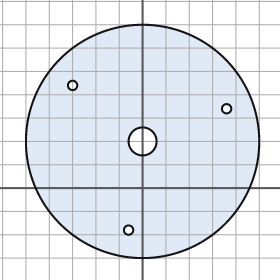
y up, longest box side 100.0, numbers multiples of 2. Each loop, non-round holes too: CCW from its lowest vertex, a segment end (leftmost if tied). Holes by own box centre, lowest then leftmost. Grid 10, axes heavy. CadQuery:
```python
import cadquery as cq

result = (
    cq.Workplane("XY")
    .moveTo(0.0, 20.0)
    .circle(50.0)
    .moveTo(-6.0, -18.0)
    .circle(2.0)
    .moveTo(0.0, 20.0)
    .circle(6.0)
    .moveTo(36.0, 34.0)
    .circle(2.0)
    .moveTo(-30.0, 44.0)
    .circle(2.0)
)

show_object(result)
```